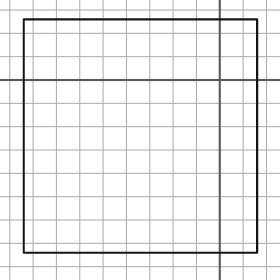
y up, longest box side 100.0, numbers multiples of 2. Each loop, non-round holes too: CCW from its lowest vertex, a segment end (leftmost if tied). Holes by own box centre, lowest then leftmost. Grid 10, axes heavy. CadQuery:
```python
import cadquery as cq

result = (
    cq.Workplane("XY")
    .moveTo(-84.0, -74.0)
    .lineTo(16.0, -74.0)
    .lineTo(16.0, 26.0)
    .lineTo(-84.0, 26.0)
    .close()
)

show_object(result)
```